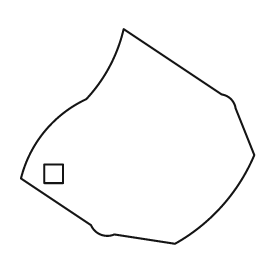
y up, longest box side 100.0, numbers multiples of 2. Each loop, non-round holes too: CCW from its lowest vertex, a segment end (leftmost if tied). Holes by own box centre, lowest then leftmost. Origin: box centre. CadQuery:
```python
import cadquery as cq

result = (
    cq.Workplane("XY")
    .moveTo(16.0, -46.0)
    .threePointArc((36.0, -30.0), (50.0, -8.0))
    .lineTo(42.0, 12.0)
    .threePointArc((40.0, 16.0), (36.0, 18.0))
    .lineTo(-6.0, 46.0)
    .threePointArc((-12.0, 30.0), (-22.0, 16.0))
    .threePointArc((-40.0, 2.0), (-50.0, -18.0))
    .lineTo(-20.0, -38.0)
    .threePointArc((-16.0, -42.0), (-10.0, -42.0))
    .close()
    .moveTo(-40.0, -20.0)
    .lineTo(-32.0, -20.0)
    .lineTo(-32.0, -12.0)
    .lineTo(-40.0, -12.0)
    .close()
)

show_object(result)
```